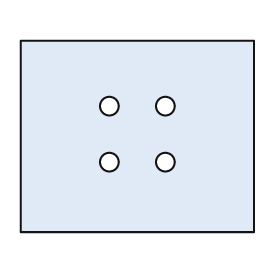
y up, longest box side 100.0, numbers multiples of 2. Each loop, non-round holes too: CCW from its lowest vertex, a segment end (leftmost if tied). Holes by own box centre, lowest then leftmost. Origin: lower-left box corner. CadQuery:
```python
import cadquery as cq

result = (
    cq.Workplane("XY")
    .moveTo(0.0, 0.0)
    .lineTo(100.0, 0.0)
    .lineTo(100.0, 82.0)
    .lineTo(0.0, 82.0)
    .close()
    .moveTo(38.0, 30.0)
    .circle(4.0)
    .moveTo(62.0, 30.0)
    .circle(4.0)
    .moveTo(38.0, 54.0)
    .circle(4.0)
    .moveTo(62.0, 54.0)
    .circle(4.0)
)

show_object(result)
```